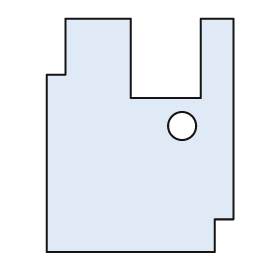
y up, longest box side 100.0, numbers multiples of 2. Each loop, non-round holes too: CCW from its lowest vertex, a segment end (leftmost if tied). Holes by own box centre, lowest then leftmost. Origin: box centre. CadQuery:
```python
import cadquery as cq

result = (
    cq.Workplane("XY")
    .moveTo(-40.0, -50.0)
    .lineTo(32.0, -50.0)
    .lineTo(32.0, -36.0)
    .lineTo(40.0, -36.0)
    .lineTo(40.0, 50.0)
    .lineTo(26.0, 50.0)
    .lineTo(26.0, 16.0)
    .lineTo(-4.0, 16.0)
    .lineTo(-4.0, 50.0)
    .lineTo(-32.0, 50.0)
    .lineTo(-32.0, 26.0)
    .lineTo(-40.0, 26.0)
    .close()
    .moveTo(18.0, 4.0)
    .circle(6.0)
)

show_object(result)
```